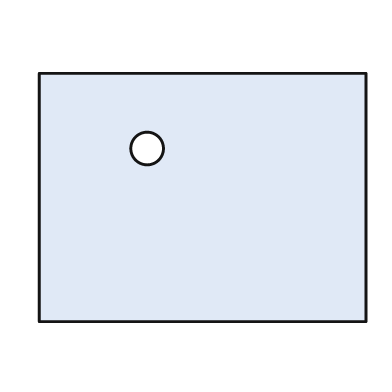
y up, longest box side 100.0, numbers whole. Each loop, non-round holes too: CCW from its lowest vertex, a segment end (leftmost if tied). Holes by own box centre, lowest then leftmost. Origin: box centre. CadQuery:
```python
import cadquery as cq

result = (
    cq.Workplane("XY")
    .moveTo(-50.0, -38.0)
    .lineTo(50.0, -38.0)
    .lineTo(50.0, 38.0)
    .lineTo(-50.0, 38.0)
    .close()
    .moveTo(-17.0, 15.0)
    .circle(5.0)
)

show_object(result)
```